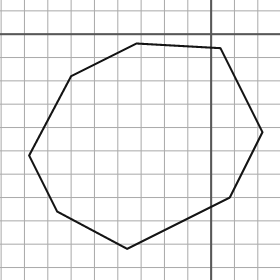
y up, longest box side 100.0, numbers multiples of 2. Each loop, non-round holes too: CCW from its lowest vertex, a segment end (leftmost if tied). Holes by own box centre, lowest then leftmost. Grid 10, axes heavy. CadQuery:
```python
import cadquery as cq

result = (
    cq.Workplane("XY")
    .moveTo(-36.0, -92.0)
    .lineTo(8.0, -70.0)
    .lineTo(22.0, -42.0)
    .lineTo(4.0, -6.0)
    .lineTo(-32.0, -4.0)
    .lineTo(-60.0, -18.0)
    .lineTo(-78.0, -52.0)
    .lineTo(-66.0, -76.0)
    .close()
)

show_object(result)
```